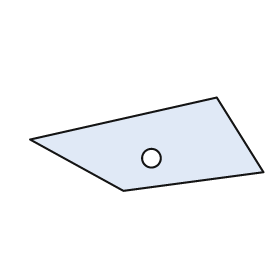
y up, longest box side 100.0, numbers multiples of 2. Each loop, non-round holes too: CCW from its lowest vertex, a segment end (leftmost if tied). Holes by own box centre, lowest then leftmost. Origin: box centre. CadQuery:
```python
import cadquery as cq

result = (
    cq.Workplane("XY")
    .moveTo(-10.0, -20.0)
    .lineTo(50.0, -12.0)
    .lineTo(30.0, 20.0)
    .lineTo(-50.0, 2.0)
    .close()
    .moveTo(2.0, -6.0)
    .circle(4.0)
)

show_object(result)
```